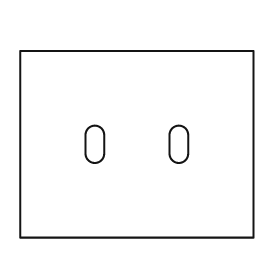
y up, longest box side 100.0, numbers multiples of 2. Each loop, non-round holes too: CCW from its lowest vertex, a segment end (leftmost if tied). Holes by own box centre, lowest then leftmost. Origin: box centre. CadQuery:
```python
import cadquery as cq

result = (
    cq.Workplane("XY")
    .moveTo(-50.0, -40.0)
    .lineTo(50.0, -40.0)
    .lineTo(50.0, 40.0)
    .lineTo(-50.0, 40.0)
    .close()
    .moveTo(-22.0, -4.0)
    .threePointArc((-18.0, -8.0), (-14.0, -4.0))
    .lineTo(-14.0, 4.0)
    .threePointArc((-18.0, 8.0), (-22.0, 4.0))
    .close()
    .moveTo(14.0, -4.0)
    .threePointArc((18.0, -8.0), (22.0, -4.0))
    .lineTo(22.0, 4.0)
    .threePointArc((18.0, 8.0), (14.0, 4.0))
    .close()
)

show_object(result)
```